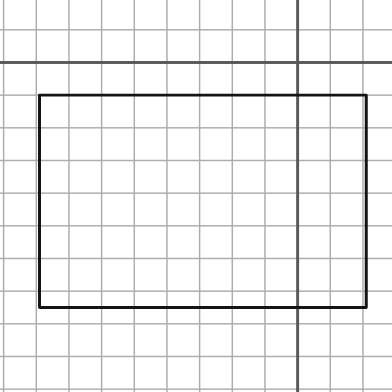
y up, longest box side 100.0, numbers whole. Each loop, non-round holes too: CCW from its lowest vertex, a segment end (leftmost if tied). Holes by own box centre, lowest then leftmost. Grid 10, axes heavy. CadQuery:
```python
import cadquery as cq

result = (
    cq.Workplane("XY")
    .moveTo(-79.0, -75.0)
    .lineTo(21.0, -75.0)
    .lineTo(21.0, -10.0)
    .lineTo(-79.0, -10.0)
    .close()
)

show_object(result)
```